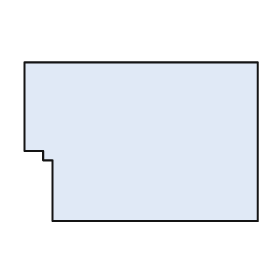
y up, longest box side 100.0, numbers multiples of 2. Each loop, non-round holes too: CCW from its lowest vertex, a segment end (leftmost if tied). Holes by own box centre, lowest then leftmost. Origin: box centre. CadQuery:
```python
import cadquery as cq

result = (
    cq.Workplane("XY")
    .moveTo(-38.0, -34.0)
    .lineTo(50.0, -34.0)
    .lineTo(50.0, 34.0)
    .lineTo(-50.0, 34.0)
    .lineTo(-50.0, -4.0)
    .lineTo(-42.0, -4.0)
    .lineTo(-42.0, -8.0)
    .lineTo(-38.0, -8.0)
    .close()
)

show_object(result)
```